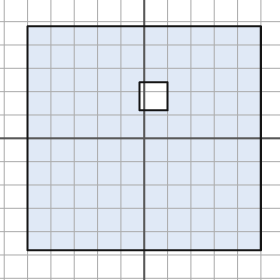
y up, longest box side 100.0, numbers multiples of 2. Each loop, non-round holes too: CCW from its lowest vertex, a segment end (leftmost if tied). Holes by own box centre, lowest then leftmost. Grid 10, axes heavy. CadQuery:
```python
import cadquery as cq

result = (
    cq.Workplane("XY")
    .moveTo(-50.0, -48.0)
    .lineTo(50.0, -48.0)
    .lineTo(50.0, 48.0)
    .lineTo(-50.0, 48.0)
    .close()
    .moveTo(-2.0, 12.0)
    .lineTo(10.0, 12.0)
    .lineTo(10.0, 24.0)
    .lineTo(-2.0, 24.0)
    .close()
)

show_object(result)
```